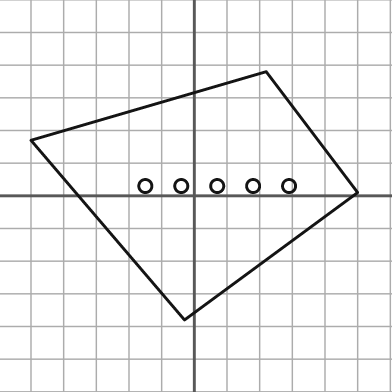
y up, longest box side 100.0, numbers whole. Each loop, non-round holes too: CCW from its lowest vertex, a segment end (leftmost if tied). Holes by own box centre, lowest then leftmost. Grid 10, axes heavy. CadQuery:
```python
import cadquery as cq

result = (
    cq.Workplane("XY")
    .moveTo(-3.0, -38.0)
    .lineTo(50.0, 1.0)
    .lineTo(22.0, 38.0)
    .lineTo(-50.0, 17.0)
    .close()
    .moveTo(-15.0, 3.0)
    .circle(2.0)
    .moveTo(-4.0, 3.0)
    .circle(2.0)
    .moveTo(7.0, 3.0)
    .circle(2.0)
    .moveTo(18.0, 3.0)
    .circle(2.0)
    .moveTo(29.0, 3.0)
    .circle(2.0)
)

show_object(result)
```